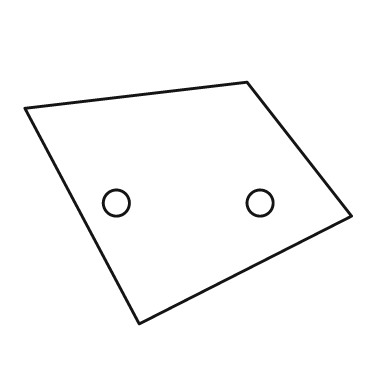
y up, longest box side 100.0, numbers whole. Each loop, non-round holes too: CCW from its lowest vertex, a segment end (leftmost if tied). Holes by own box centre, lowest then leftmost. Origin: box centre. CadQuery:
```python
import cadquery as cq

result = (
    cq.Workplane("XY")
    .moveTo(-15.0, -37.0)
    .lineTo(50.0, -4.0)
    .lineTo(18.0, 37.0)
    .lineTo(-50.0, 29.0)
    .close()
    .moveTo(-22.0, 0.0)
    .circle(4.0)
    .moveTo(22.0, 0.0)
    .circle(4.0)
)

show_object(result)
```